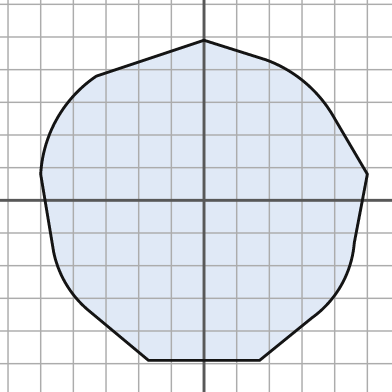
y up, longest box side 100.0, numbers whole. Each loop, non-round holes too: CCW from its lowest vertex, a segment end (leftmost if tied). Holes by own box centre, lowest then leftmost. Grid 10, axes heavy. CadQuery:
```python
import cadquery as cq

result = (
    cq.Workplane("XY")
    .moveTo(-17.0, -49.0)
    .lineTo(17.0, -49.0)
    .lineTo(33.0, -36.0)
    .threePointArc((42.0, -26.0), (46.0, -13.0))
    .lineTo(50.0, 8.0)
    .lineTo(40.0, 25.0)
    .threePointArc((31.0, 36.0), (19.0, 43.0))
    .lineTo(0.0, 49.0)
    .lineTo(-33.0, 38.0)
    .threePointArc((-45.0, 25.0), (-50.0, 8.0))
    .lineTo(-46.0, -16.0)
    .threePointArc((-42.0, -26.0), (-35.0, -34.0))
    .close()
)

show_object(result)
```